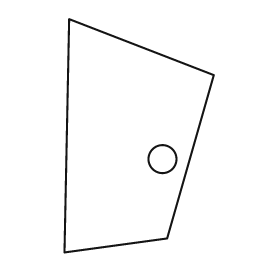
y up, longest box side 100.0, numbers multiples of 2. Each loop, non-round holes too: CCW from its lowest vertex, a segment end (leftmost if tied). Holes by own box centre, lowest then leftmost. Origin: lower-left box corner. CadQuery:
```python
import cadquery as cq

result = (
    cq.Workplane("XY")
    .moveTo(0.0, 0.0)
    .lineTo(44.0, 6.0)
    .lineTo(64.0, 76.0)
    .lineTo(2.0, 100.0)
    .close()
    .moveTo(42.0, 40.0)
    .circle(6.0)
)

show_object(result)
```